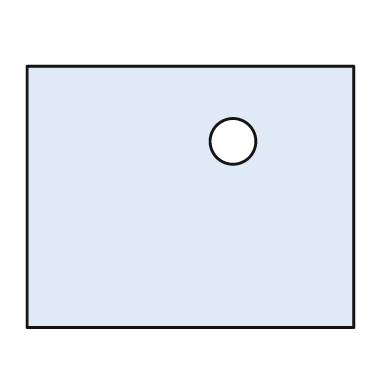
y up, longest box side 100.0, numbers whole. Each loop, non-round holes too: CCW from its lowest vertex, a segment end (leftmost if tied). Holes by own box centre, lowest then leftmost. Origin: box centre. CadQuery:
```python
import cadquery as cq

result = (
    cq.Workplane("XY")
    .moveTo(-50.0, -40.0)
    .lineTo(50.0, -40.0)
    .lineTo(50.0, 40.0)
    .lineTo(-50.0, 40.0)
    .close()
    .moveTo(13.0, 17.0)
    .circle(7.0)
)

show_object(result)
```